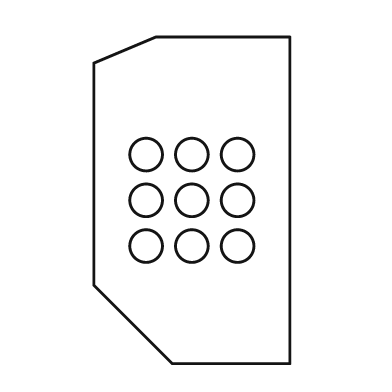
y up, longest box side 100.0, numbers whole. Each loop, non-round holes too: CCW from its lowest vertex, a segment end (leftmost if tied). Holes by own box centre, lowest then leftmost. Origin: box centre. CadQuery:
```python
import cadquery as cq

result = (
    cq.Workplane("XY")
    .moveTo(-6.0, -50.0)
    .lineTo(30.0, -50.0)
    .lineTo(30.0, 50.0)
    .lineTo(-11.0, 50.0)
    .lineTo(-30.0, 42.0)
    .lineTo(-30.0, -26.0)
    .close()
    .moveTo(-14.0, -14.0)
    .circle(5.0)
    .moveTo(0.0, -14.0)
    .circle(5.0)
    .moveTo(14.0, -14.0)
    .circle(5.0)
    .moveTo(-14.0, 0.0)
    .circle(5.0)
    .moveTo(0.0, 0.0)
    .circle(5.0)
    .moveTo(14.0, 0.0)
    .circle(5.0)
    .moveTo(-14.0, 14.0)
    .circle(5.0)
    .moveTo(0.0, 14.0)
    .circle(5.0)
    .moveTo(14.0, 14.0)
    .circle(5.0)
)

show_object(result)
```